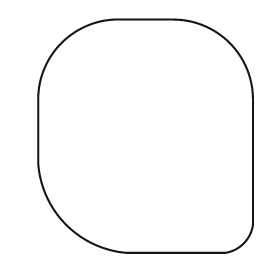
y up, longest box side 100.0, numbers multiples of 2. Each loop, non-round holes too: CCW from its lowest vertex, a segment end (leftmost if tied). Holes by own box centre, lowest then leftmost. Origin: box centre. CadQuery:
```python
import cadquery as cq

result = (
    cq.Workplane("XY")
    .moveTo(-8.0, -50.0)
    .lineTo(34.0, -50.0)
    .threePointArc((42.0, -46.0), (46.0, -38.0))
    .lineTo(46.0, 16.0)
    .threePointArc((36.0, 40.0), (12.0, 50.0))
    .lineTo(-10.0, 50.0)
    .threePointArc((-36.0, 40.0), (-46.0, 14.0))
    .lineTo(-46.0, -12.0)
    .threePointArc((-34.0, -38.0), (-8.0, -50.0))
    .close()
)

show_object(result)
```